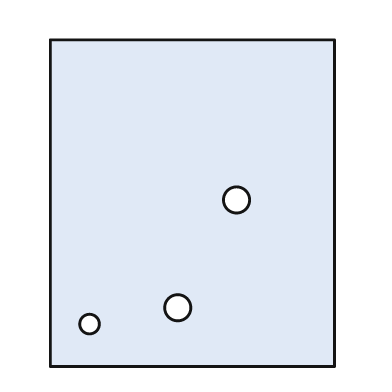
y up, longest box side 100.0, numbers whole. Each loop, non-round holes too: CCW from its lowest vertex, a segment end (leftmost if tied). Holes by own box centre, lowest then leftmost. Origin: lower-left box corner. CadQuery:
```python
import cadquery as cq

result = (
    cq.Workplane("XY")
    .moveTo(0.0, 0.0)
    .lineTo(87.0, 0.0)
    .lineTo(87.0, 100.0)
    .lineTo(0.0, 100.0)
    .close()
    .moveTo(12.0, 13.0)
    .circle(3.0)
    .moveTo(39.0, 18.0)
    .circle(4.0)
    .moveTo(57.0, 51.0)
    .circle(4.0)
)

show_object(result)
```